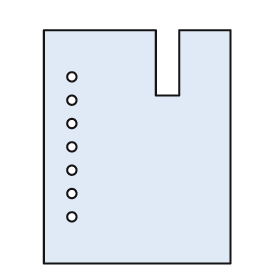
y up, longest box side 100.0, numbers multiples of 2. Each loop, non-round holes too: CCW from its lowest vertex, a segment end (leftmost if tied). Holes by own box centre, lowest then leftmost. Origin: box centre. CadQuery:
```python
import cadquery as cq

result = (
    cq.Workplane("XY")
    .moveTo(-40.0, -50.0)
    .lineTo(40.0, -50.0)
    .lineTo(40.0, 50.0)
    .lineTo(18.0, 50.0)
    .lineTo(18.0, 22.0)
    .lineTo(8.0, 22.0)
    .lineTo(8.0, 50.0)
    .lineTo(-40.0, 50.0)
    .close()
    .moveTo(-28.0, -30.0)
    .circle(2.0)
    .moveTo(-28.0, -20.0)
    .circle(2.0)
    .moveTo(-28.0, -10.0)
    .circle(2.0)
    .moveTo(-28.0, 0.0)
    .circle(2.0)
    .moveTo(-28.0, 10.0)
    .circle(2.0)
    .moveTo(-28.0, 20.0)
    .circle(2.0)
    .moveTo(-28.0, 30.0)
    .circle(2.0)
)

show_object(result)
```